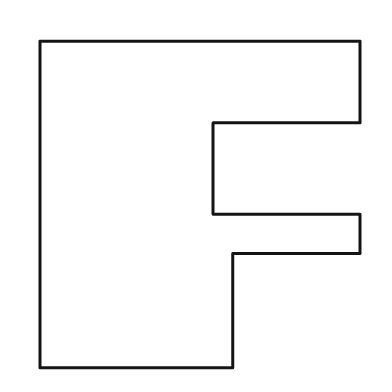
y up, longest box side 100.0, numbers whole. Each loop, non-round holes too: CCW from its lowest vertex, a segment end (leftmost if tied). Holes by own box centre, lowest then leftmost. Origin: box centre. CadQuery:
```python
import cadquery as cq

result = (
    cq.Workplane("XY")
    .moveTo(-49.0, -50.0)
    .lineTo(10.0, -50.0)
    .lineTo(10.0, -15.0)
    .lineTo(49.0, -15.0)
    .lineTo(49.0, -3.0)
    .lineTo(4.0, -3.0)
    .lineTo(4.0, 25.0)
    .lineTo(49.0, 25.0)
    .lineTo(49.0, 50.0)
    .lineTo(-49.0, 50.0)
    .close()
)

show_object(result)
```